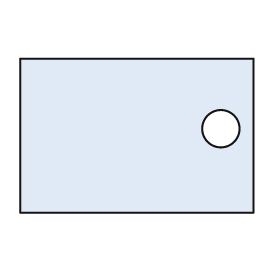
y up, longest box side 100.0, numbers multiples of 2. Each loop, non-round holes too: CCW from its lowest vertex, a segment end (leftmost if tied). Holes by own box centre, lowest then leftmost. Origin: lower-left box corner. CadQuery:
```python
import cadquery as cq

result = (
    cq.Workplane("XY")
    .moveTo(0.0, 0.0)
    .lineTo(100.0, 0.0)
    .lineTo(100.0, 66.0)
    .lineTo(0.0, 66.0)
    .close()
    .moveTo(86.0, 36.0)
    .circle(8.0)
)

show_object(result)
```